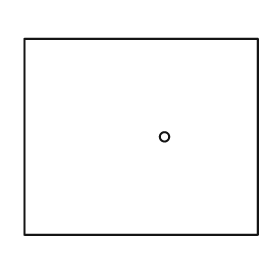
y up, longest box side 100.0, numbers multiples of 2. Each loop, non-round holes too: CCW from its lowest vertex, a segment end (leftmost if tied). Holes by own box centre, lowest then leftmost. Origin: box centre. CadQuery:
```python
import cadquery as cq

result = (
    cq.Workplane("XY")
    .moveTo(-50.0, -42.0)
    .lineTo(50.0, -42.0)
    .lineTo(50.0, 42.0)
    .lineTo(-50.0, 42.0)
    .close()
    .moveTo(10.0, 0.0)
    .circle(2.0)
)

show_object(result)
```